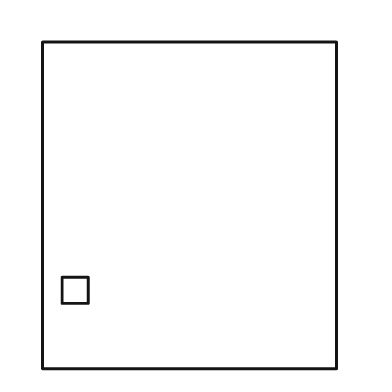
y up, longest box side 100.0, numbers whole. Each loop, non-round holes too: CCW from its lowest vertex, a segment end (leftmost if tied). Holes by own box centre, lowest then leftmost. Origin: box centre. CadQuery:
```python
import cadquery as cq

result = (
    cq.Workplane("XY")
    .moveTo(-45.0, -50.0)
    .lineTo(45.0, -50.0)
    .lineTo(45.0, 50.0)
    .lineTo(-45.0, 50.0)
    .close()
    .moveTo(-39.0, -30.0)
    .lineTo(-31.0, -30.0)
    .lineTo(-31.0, -22.0)
    .lineTo(-39.0, -22.0)
    .close()
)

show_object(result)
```